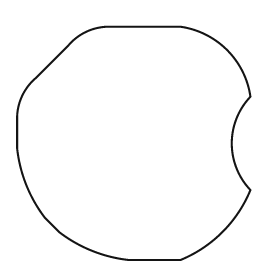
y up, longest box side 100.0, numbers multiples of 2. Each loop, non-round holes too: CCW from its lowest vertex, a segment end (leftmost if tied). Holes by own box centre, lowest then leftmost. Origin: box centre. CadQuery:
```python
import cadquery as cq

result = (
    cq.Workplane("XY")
    .moveTo(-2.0, -50.0)
    .lineTo(20.0, -50.0)
    .threePointArc((38.0, -38.0), (50.0, -20.0))
    .threePointArc((42.0, 0.0), (50.0, 20.0))
    .threePointArc((40.0, 40.0), (20.0, 50.0))
    .lineTo(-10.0, 50.0)
    .threePointArc((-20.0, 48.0), (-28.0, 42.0))
    .lineTo(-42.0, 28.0)
    .threePointArc((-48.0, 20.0), (-50.0, 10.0))
    .lineTo(-50.0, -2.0)
    .threePointArc((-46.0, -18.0), (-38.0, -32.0))
    .lineTo(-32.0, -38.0)
    .threePointArc((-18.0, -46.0), (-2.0, -50.0))
    .close()
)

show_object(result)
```